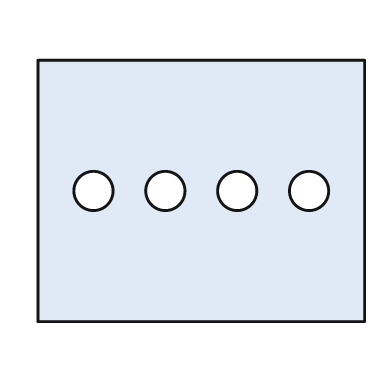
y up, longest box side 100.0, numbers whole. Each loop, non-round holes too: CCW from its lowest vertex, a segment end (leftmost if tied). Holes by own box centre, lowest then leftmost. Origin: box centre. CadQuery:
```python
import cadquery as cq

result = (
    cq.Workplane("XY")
    .moveTo(-50.0, -40.0)
    .lineTo(50.0, -40.0)
    .lineTo(50.0, 40.0)
    .lineTo(-50.0, 40.0)
    .close()
    .moveTo(-33.0, 0.0)
    .circle(6.0)
    .moveTo(-11.0, 0.0)
    .circle(6.0)
    .moveTo(11.0, 0.0)
    .circle(6.0)
    .moveTo(33.0, 0.0)
    .circle(6.0)
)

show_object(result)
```